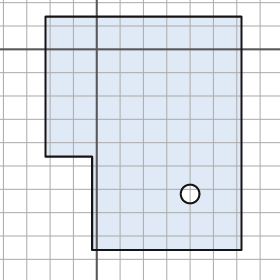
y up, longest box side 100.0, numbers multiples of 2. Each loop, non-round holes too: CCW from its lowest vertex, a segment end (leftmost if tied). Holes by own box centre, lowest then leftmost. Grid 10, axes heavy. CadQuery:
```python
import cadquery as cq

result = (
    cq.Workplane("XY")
    .moveTo(-2.0, -86.0)
    .lineTo(62.0, -86.0)
    .lineTo(62.0, 14.0)
    .lineTo(-22.0, 14.0)
    .lineTo(-22.0, -46.0)
    .lineTo(-2.0, -46.0)
    .close()
    .moveTo(40.0, -62.0)
    .circle(4.0)
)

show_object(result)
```